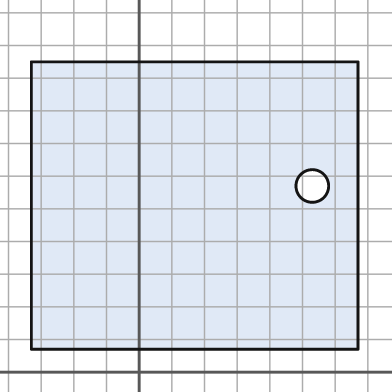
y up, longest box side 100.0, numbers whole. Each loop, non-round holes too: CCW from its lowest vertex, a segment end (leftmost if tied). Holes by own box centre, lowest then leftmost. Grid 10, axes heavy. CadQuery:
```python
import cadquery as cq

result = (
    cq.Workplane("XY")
    .moveTo(-33.0, 7.0)
    .lineTo(67.0, 7.0)
    .lineTo(67.0, 95.0)
    .lineTo(-33.0, 95.0)
    .close()
    .moveTo(53.0, 57.0)
    .circle(5.0)
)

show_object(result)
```